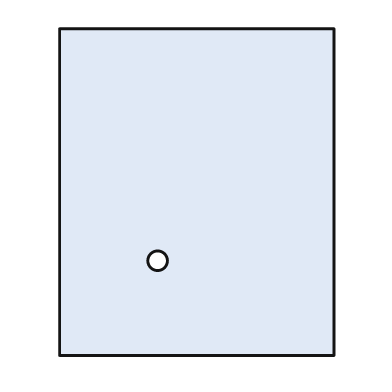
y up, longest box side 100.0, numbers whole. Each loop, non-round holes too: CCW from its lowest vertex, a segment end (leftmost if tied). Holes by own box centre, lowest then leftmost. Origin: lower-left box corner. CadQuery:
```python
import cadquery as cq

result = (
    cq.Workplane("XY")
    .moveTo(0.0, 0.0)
    .lineTo(84.0, 0.0)
    .lineTo(84.0, 100.0)
    .lineTo(0.0, 100.0)
    .close()
    .moveTo(30.0, 29.0)
    .circle(3.0)
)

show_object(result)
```